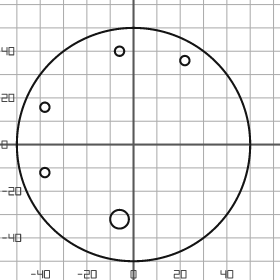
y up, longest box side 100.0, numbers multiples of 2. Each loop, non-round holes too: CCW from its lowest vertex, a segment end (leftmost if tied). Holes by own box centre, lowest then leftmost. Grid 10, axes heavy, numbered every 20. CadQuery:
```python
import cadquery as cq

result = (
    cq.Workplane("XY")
    .moveTo(0.0, 0.0)
    .circle(50.0)
    .moveTo(-6.0, -32.0)
    .circle(4.0)
    .moveTo(-38.0, -12.0)
    .circle(2.0)
    .moveTo(-38.0, 16.0)
    .circle(2.0)
    .moveTo(22.0, 36.0)
    .circle(2.0)
    .moveTo(-6.0, 40.0)
    .circle(2.0)
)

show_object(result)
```